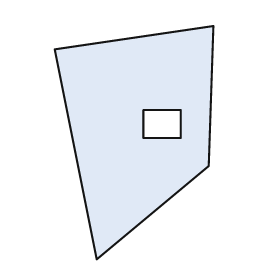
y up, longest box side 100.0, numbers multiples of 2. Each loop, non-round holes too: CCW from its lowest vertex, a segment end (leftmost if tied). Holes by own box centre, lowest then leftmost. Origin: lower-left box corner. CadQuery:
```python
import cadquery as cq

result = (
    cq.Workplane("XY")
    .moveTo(18.0, 0.0)
    .lineTo(66.0, 40.0)
    .lineTo(68.0, 100.0)
    .lineTo(0.0, 90.0)
    .close()
    .moveTo(38.0, 52.0)
    .lineTo(54.0, 52.0)
    .lineTo(54.0, 64.0)
    .lineTo(38.0, 64.0)
    .close()
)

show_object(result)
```